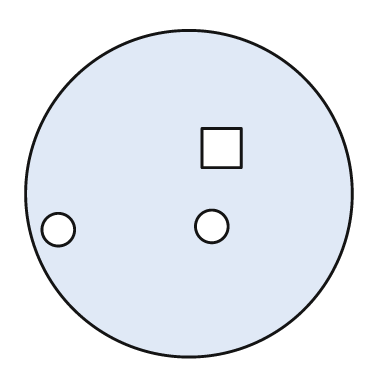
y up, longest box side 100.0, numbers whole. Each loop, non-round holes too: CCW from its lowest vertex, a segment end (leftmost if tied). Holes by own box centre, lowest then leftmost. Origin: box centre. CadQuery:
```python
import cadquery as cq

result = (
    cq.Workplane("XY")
    .moveTo(0.0, 0.0)
    .circle(50.0)
    .moveTo(-40.0, -11.0)
    .circle(5.0)
    .moveTo(7.0, -10.0)
    .circle(5.0)
    .moveTo(4.0, 8.0)
    .lineTo(16.0, 8.0)
    .lineTo(16.0, 20.0)
    .lineTo(4.0, 20.0)
    .close()
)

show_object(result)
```